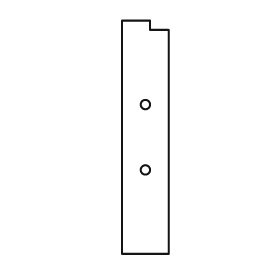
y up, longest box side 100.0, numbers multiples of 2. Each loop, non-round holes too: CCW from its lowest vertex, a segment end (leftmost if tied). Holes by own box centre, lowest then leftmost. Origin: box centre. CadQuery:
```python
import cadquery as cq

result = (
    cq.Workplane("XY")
    .moveTo(-10.0, -50.0)
    .lineTo(10.0, -50.0)
    .lineTo(10.0, 46.0)
    .lineTo(2.0, 46.0)
    .lineTo(2.0, 50.0)
    .lineTo(-10.0, 50.0)
    .close()
    .moveTo(0.0, -14.0)
    .circle(2.0)
    .moveTo(0.0, 14.0)
    .circle(2.0)
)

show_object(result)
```